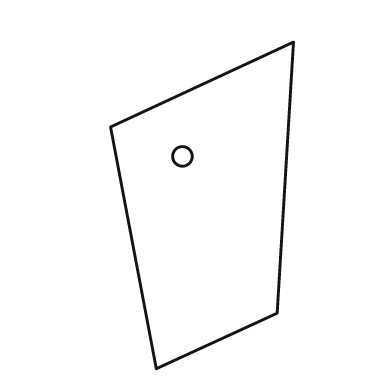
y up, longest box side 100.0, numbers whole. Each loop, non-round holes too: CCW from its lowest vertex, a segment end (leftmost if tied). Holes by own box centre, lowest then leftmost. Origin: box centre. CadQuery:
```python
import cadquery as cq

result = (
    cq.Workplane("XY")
    .moveTo(-14.0, -50.0)
    .lineTo(23.0, -33.0)
    .lineTo(28.0, 50.0)
    .lineTo(-28.0, 24.0)
    .close()
    .moveTo(-6.0, 15.0)
    .circle(3.0)
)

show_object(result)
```